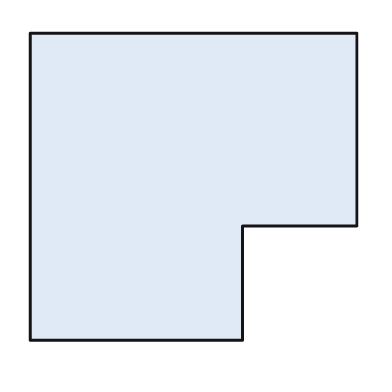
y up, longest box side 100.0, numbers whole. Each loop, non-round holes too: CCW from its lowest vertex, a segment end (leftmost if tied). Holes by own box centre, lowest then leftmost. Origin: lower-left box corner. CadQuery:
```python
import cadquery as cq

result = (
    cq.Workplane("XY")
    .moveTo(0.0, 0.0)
    .lineTo(65.0, 0.0)
    .lineTo(65.0, 35.0)
    .lineTo(100.0, 35.0)
    .lineTo(100.0, 94.0)
    .lineTo(0.0, 94.0)
    .close()
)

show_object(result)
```